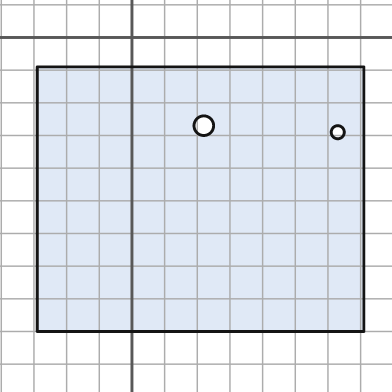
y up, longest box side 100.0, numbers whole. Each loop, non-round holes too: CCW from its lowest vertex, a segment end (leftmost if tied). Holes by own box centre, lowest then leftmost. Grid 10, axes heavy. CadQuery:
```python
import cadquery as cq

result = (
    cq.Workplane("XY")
    .moveTo(-29.0, -90.0)
    .lineTo(71.0, -90.0)
    .lineTo(71.0, -9.0)
    .lineTo(-29.0, -9.0)
    .close()
    .moveTo(63.0, -29.0)
    .circle(2.0)
    .moveTo(22.0, -27.0)
    .circle(3.0)
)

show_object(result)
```